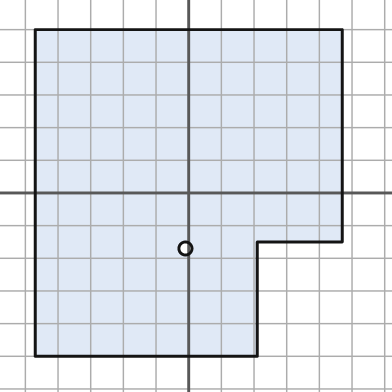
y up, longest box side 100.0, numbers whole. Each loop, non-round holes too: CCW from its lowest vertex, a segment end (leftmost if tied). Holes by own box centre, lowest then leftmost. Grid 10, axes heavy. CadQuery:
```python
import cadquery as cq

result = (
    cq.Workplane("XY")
    .moveTo(-47.0, -50.0)
    .lineTo(21.0, -50.0)
    .lineTo(21.0, -15.0)
    .lineTo(47.0, -15.0)
    .lineTo(47.0, 50.0)
    .lineTo(-47.0, 50.0)
    .close()
    .moveTo(-1.0, -17.0)
    .circle(2.0)
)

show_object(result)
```